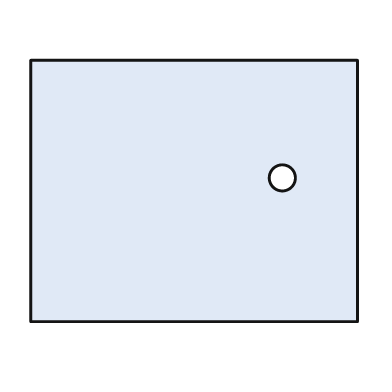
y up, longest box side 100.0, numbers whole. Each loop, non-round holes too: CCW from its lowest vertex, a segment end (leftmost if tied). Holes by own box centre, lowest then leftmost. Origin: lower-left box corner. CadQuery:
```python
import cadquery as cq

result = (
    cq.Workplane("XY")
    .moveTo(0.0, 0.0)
    .lineTo(100.0, 0.0)
    .lineTo(100.0, 80.0)
    .lineTo(0.0, 80.0)
    .close()
    .moveTo(77.0, 44.0)
    .circle(4.0)
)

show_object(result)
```